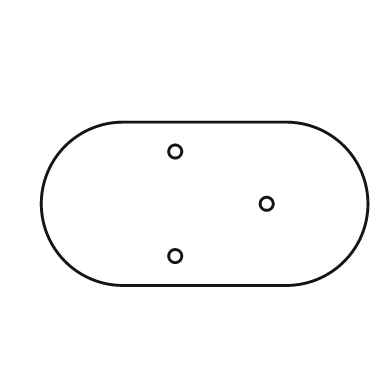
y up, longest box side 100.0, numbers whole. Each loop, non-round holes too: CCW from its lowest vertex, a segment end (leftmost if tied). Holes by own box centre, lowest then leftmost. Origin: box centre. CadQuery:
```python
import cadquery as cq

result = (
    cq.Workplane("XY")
    .moveTo(-25.0, -25.0)
    .lineTo(25.0, -25.0)
    .threePointArc((50.0, 0.0), (25.0, 25.0))
    .lineTo(-25.0, 25.0)
    .threePointArc((-50.0, 0.0), (-25.0, -25.0))
    .close()
    .moveTo(-9.0, -16.0)
    .circle(2.0)
    .moveTo(19.0, 0.0)
    .circle(2.0)
    .moveTo(-9.0, 16.0)
    .circle(2.0)
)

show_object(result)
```